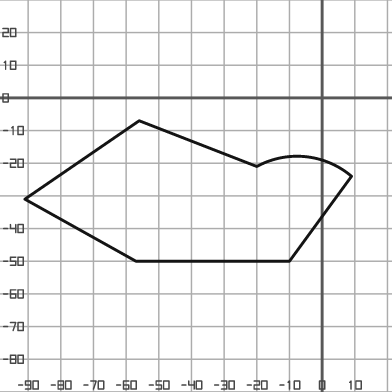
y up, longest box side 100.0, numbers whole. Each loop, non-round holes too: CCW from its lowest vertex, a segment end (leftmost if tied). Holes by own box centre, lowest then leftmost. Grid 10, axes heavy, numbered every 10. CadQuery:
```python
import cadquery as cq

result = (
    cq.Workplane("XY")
    .moveTo(-57.0, -50.0)
    .lineTo(-10.0, -50.0)
    .lineTo(9.0, -24.0)
    .threePointArc((-5.0, -18.0), (-20.0, -21.0))
    .lineTo(-56.0, -7.0)
    .lineTo(-91.0, -31.0)
    .close()
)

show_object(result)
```